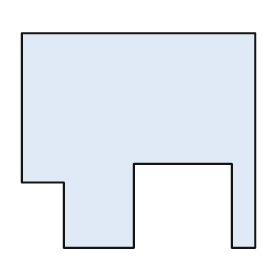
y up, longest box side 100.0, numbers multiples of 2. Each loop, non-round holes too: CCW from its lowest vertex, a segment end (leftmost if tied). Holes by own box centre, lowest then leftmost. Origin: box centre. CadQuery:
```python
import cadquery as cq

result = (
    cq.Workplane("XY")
    .moveTo(-32.0, -46.0)
    .lineTo(-2.0, -46.0)
    .lineTo(-2.0, -10.0)
    .lineTo(40.0, -10.0)
    .lineTo(40.0, -46.0)
    .lineTo(50.0, -46.0)
    .lineTo(50.0, 46.0)
    .lineTo(-50.0, 46.0)
    .lineTo(-50.0, -18.0)
    .lineTo(-32.0, -18.0)
    .close()
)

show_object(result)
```